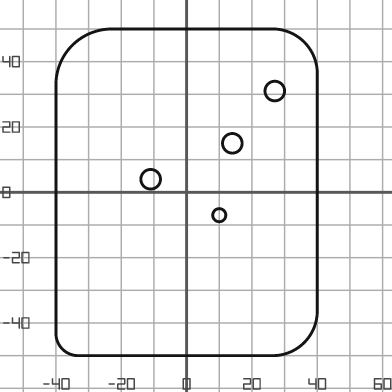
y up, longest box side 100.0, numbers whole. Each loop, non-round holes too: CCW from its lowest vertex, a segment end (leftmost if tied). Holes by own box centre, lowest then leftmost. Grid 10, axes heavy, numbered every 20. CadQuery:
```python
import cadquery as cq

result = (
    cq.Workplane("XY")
    .moveTo(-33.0, -50.0)
    .lineTo(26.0, -50.0)
    .threePointArc((36.0, -46.0), (40.0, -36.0))
    .lineTo(40.0, 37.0)
    .threePointArc((36.0, 46.0), (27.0, 50.0))
    .lineTo(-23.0, 50.0)
    .threePointArc((-35.0, 45.0), (-40.0, 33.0))
    .lineTo(-40.0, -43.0)
    .threePointArc((-38.0, -48.0), (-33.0, -50.0))
    .close()
    .moveTo(10.0, -7.0)
    .circle(2.0)
    .moveTo(-11.0, 4.0)
    .circle(3.0)
    .moveTo(14.0, 15.0)
    .circle(3.0)
    .moveTo(27.0, 31.0)
    .circle(3.0)
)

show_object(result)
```